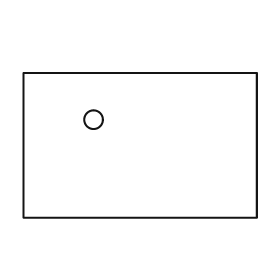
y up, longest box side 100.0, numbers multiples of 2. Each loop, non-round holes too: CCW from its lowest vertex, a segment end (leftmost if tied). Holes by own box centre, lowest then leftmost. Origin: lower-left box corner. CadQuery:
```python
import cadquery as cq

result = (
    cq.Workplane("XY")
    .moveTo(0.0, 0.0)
    .lineTo(100.0, 0.0)
    .lineTo(100.0, 62.0)
    .lineTo(0.0, 62.0)
    .close()
    .moveTo(30.0, 42.0)
    .circle(4.0)
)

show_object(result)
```